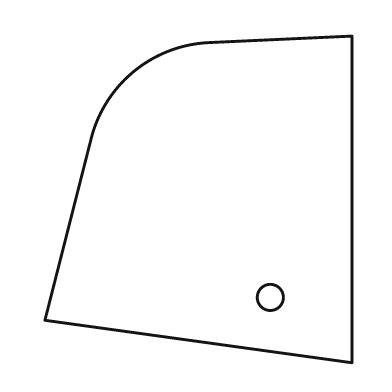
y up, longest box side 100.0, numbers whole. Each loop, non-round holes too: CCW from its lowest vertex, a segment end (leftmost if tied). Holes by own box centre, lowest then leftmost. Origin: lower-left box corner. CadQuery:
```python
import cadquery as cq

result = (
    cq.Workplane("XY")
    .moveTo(94.0, 0.0)
    .lineTo(94.0, 100.0)
    .lineTo(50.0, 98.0)
    .threePointArc((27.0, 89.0), (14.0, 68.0))
    .lineTo(0.0, 13.0)
    .close()
    .moveTo(69.0, 20.0)
    .circle(4.0)
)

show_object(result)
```